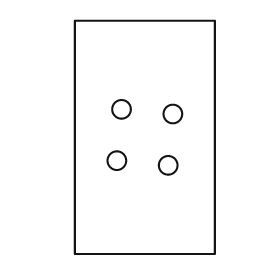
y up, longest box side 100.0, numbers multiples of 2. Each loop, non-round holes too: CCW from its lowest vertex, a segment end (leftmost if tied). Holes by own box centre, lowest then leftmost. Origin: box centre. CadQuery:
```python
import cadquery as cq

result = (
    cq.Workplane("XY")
    .moveTo(-30.0, -50.0)
    .lineTo(30.0, -50.0)
    .lineTo(30.0, 50.0)
    .lineTo(-30.0, 50.0)
    .close()
    .moveTo(10.0, -12.0)
    .circle(4.0)
    .moveTo(-12.0, -10.0)
    .circle(4.0)
    .moveTo(12.0, 10.0)
    .circle(4.0)
    .moveTo(-10.0, 12.0)
    .circle(4.0)
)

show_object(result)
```